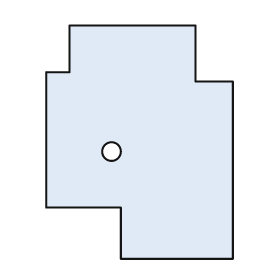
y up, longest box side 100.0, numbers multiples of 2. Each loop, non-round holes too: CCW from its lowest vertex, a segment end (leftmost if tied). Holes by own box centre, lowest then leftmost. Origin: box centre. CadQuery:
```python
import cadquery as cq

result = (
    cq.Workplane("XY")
    .moveTo(-8.0, -50.0)
    .lineTo(40.0, -50.0)
    .lineTo(40.0, 26.0)
    .lineTo(24.0, 26.0)
    .lineTo(24.0, 50.0)
    .lineTo(-30.0, 50.0)
    .lineTo(-30.0, 30.0)
    .lineTo(-40.0, 30.0)
    .lineTo(-40.0, -28.0)
    .lineTo(-8.0, -28.0)
    .close()
    .moveTo(-12.0, -4.0)
    .circle(4.0)
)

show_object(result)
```